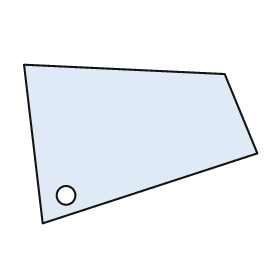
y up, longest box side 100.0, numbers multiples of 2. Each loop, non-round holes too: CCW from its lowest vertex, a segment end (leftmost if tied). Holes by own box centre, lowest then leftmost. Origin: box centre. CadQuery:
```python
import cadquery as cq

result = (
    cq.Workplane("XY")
    .moveTo(-42.0, -34.0)
    .lineTo(50.0, -4.0)
    .lineTo(36.0, 30.0)
    .lineTo(-50.0, 34.0)
    .close()
    .moveTo(-32.0, -22.0)
    .circle(4.0)
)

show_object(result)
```